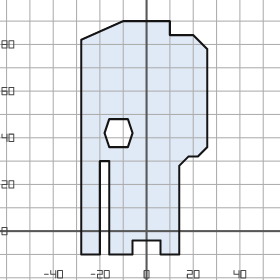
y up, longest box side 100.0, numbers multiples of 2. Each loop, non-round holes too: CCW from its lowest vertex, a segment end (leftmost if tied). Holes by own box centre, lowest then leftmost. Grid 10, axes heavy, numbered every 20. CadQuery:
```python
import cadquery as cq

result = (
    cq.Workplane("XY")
    .moveTo(-28.0, -10.0)
    .lineTo(-20.0, -10.0)
    .lineTo(-20.0, 30.0)
    .lineTo(-16.0, 30.0)
    .lineTo(-16.0, -10.0)
    .lineTo(-6.0, -10.0)
    .lineTo(-6.0, -4.0)
    .lineTo(6.0, -4.0)
    .lineTo(6.0, -10.0)
    .lineTo(14.0, -10.0)
    .lineTo(14.0, 28.0)
    .lineTo(18.0, 32.0)
    .lineTo(22.0, 32.0)
    .lineTo(26.0, 36.0)
    .lineTo(26.0, 78.0)
    .lineTo(20.0, 84.0)
    .lineTo(10.0, 84.0)
    .lineTo(10.0, 90.0)
    .lineTo(-10.0, 90.0)
    .lineTo(-28.0, 82.0)
    .close()
    .moveTo(-16.0, 36.0)
    .lineTo(-8.0, 36.0)
    .lineTo(-6.0, 42.0)
    .lineTo(-8.0, 48.0)
    .lineTo(-16.0, 48.0)
    .lineTo(-18.0, 42.0)
    .close()
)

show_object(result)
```